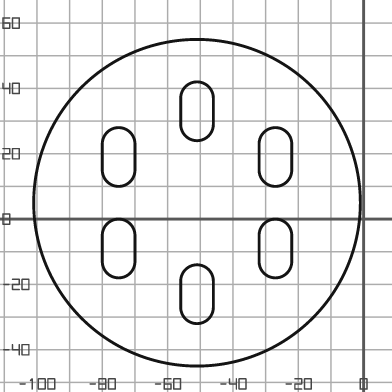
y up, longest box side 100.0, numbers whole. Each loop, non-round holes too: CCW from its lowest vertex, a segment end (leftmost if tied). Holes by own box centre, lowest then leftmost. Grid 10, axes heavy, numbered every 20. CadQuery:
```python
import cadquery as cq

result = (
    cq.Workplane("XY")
    .moveTo(-51.0, 5.0)
    .circle(50.0)
    .moveTo(-56.0, -27.0)
    .threePointArc((-51.0, -32.0), (-46.0, -27.0))
    .lineTo(-46.0, -19.0)
    .threePointArc((-51.0, -14.0), (-56.0, -19.0))
    .close()
    .moveTo(-80.0, -13.0)
    .threePointArc((-75.0, -18.0), (-70.0, -13.0))
    .lineTo(-70.0, -5.0)
    .threePointArc((-75.0, 0.0), (-80.0, -5.0))
    .close()
    .moveTo(-32.0, -13.0)
    .threePointArc((-27.0, -18.0), (-22.0, -13.0))
    .lineTo(-22.0, -5.0)
    .threePointArc((-27.0, 0.0), (-32.0, -5.0))
    .close()
    .moveTo(-80.0, 15.0)
    .threePointArc((-75.0, 10.0), (-70.0, 15.0))
    .lineTo(-70.0, 23.0)
    .threePointArc((-75.0, 28.0), (-80.0, 23.0))
    .close()
    .moveTo(-32.0, 15.0)
    .threePointArc((-27.0, 10.0), (-22.0, 15.0))
    .lineTo(-22.0, 23.0)
    .threePointArc((-27.0, 28.0), (-32.0, 23.0))
    .close()
    .moveTo(-56.0, 29.0)
    .threePointArc((-51.0, 24.0), (-46.0, 29.0))
    .lineTo(-46.0, 37.0)
    .threePointArc((-51.0, 42.0), (-56.0, 37.0))
    .close()
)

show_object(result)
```